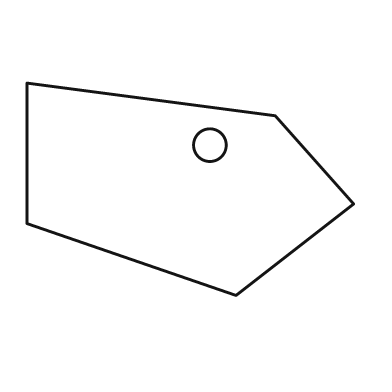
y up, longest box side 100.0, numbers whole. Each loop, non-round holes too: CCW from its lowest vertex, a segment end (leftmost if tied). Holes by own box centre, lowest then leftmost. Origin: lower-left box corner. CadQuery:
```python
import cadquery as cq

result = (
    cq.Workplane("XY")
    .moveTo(64.0, 0.0)
    .lineTo(100.0, 28.0)
    .lineTo(76.0, 55.0)
    .lineTo(0.0, 65.0)
    .lineTo(0.0, 22.0)
    .close()
    .moveTo(56.0, 46.0)
    .circle(5.0)
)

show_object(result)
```